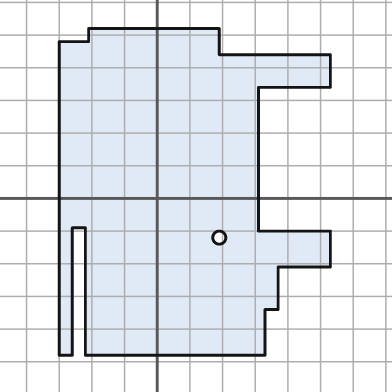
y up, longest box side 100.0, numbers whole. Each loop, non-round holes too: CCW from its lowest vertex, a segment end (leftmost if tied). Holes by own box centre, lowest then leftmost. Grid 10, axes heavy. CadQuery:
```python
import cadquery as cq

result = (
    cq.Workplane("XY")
    .moveTo(-30.0, -48.0)
    .lineTo(-26.0, -48.0)
    .lineTo(-26.0, -9.0)
    .lineTo(-22.0, -9.0)
    .lineTo(-22.0, -48.0)
    .lineTo(33.0, -48.0)
    .lineTo(33.0, -34.0)
    .lineTo(37.0, -34.0)
    .lineTo(37.0, -21.0)
    .lineTo(53.0, -21.0)
    .lineTo(53.0, -10.0)
    .lineTo(31.0, -10.0)
    .lineTo(31.0, 34.0)
    .lineTo(53.0, 34.0)
    .lineTo(53.0, 44.0)
    .lineTo(19.0, 44.0)
    .lineTo(19.0, 52.0)
    .lineTo(-21.0, 52.0)
    .lineTo(-21.0, 48.0)
    .lineTo(-30.0, 48.0)
    .close()
    .moveTo(19.0, -12.0)
    .circle(2.0)
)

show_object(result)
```